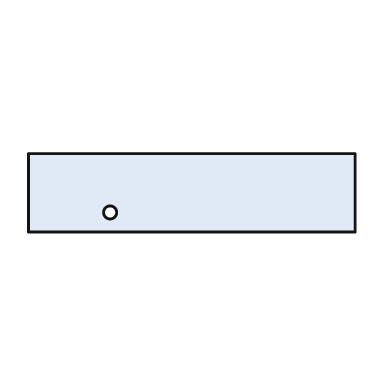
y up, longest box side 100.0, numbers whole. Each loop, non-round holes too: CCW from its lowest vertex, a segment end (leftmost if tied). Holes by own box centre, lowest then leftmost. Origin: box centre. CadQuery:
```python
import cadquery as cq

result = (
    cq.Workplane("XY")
    .moveTo(-50.0, -12.0)
    .lineTo(50.0, -12.0)
    .lineTo(50.0, 12.0)
    .lineTo(-50.0, 12.0)
    .close()
    .moveTo(-25.0, -6.0)
    .circle(2.0)
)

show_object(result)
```